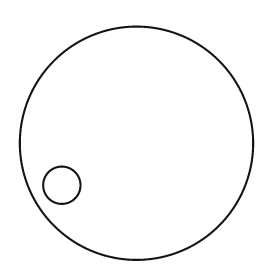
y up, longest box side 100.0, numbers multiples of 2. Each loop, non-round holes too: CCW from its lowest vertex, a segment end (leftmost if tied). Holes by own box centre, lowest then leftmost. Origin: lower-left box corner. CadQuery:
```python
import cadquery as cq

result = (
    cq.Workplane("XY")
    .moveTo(50.0, 50.0)
    .circle(50.0)
    .moveTo(18.0, 32.0)
    .circle(8.0)
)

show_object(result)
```